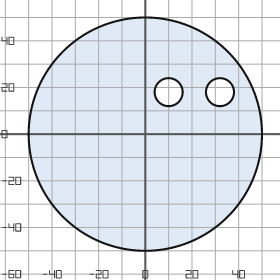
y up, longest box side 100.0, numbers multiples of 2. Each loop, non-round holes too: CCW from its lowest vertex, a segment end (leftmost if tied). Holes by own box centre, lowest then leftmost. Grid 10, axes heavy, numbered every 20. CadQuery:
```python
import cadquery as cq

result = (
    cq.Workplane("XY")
    .moveTo(0.0, 0.0)
    .circle(50.0)
    .moveTo(10.0, 18.0)
    .circle(6.0)
    .moveTo(32.0, 18.0)
    .circle(6.0)
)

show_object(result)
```